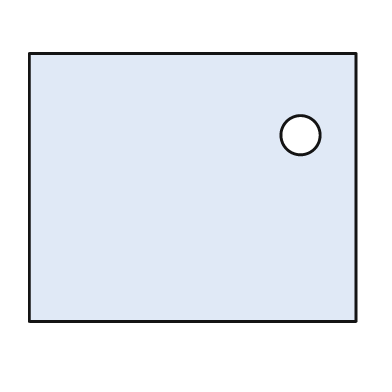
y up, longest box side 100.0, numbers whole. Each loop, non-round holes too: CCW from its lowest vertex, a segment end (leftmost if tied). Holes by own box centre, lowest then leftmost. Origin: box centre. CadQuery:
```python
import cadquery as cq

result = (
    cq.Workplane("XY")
    .moveTo(-50.0, -41.0)
    .lineTo(50.0, -41.0)
    .lineTo(50.0, 41.0)
    .lineTo(-50.0, 41.0)
    .close()
    .moveTo(33.0, 16.0)
    .circle(6.0)
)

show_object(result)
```